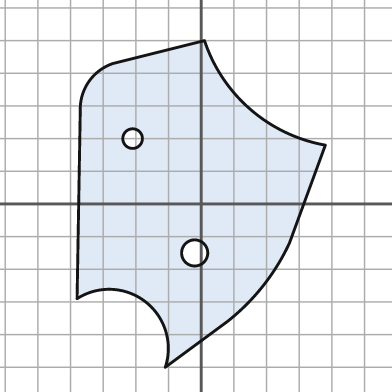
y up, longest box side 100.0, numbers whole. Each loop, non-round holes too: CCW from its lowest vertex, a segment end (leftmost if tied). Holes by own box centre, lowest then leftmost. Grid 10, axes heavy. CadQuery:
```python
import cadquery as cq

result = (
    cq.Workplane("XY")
    .moveTo(-11.0, -50.0)
    .lineTo(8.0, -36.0)
    .threePointArc((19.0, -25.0), (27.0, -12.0))
    .lineTo(38.0, 18.0)
    .threePointArc((15.0, 29.0), (1.0, 50.0))
    .lineTo(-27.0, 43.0)
    .threePointArc((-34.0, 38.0), (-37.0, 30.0))
    .lineTo(-38.0, -29.0)
    .threePointArc((-17.0, -30.0), (-11.0, -50.0))
    .close()
    .moveTo(-2.0, -15.0)
    .circle(4.0)
    .moveTo(-21.0, 20.0)
    .circle(3.0)
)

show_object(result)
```